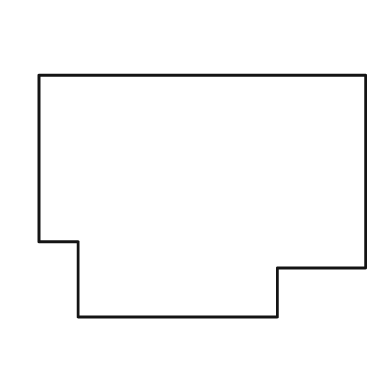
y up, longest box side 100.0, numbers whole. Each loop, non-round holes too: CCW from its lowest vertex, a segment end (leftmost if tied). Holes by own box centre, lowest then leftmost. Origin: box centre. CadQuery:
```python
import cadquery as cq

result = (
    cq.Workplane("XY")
    .moveTo(-38.0, -37.0)
    .lineTo(23.0, -37.0)
    .lineTo(23.0, -22.0)
    .lineTo(50.0, -22.0)
    .lineTo(50.0, 37.0)
    .lineTo(-50.0, 37.0)
    .lineTo(-50.0, -14.0)
    .lineTo(-38.0, -14.0)
    .close()
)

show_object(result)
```